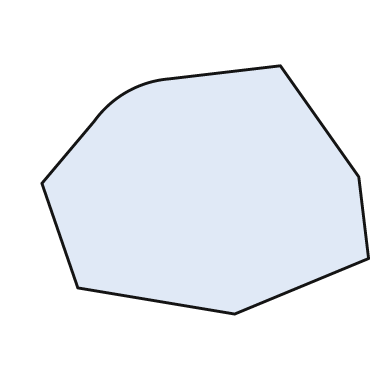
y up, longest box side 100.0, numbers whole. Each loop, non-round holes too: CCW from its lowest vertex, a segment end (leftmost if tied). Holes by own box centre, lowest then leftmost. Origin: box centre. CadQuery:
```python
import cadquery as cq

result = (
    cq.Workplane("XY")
    .moveTo(9.0, -38.0)
    .lineTo(50.0, -21.0)
    .lineTo(47.0, 4.0)
    .lineTo(23.0, 38.0)
    .lineTo(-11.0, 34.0)
    .threePointArc((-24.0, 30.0), (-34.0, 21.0))
    .lineTo(-50.0, 2.0)
    .lineTo(-39.0, -30.0)
    .close()
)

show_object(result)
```